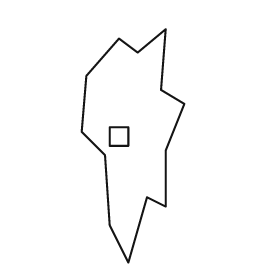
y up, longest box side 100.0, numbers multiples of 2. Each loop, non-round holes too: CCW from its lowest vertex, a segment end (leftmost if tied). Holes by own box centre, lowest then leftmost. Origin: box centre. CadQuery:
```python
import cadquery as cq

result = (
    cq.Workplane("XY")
    .moveTo(-2.0, -50.0)
    .lineTo(6.0, -22.0)
    .lineTo(14.0, -26.0)
    .lineTo(14.0, -2.0)
    .lineTo(22.0, 18.0)
    .lineTo(12.0, 24.0)
    .lineTo(14.0, 50.0)
    .lineTo(2.0, 40.0)
    .lineTo(-6.0, 46.0)
    .lineTo(-20.0, 30.0)
    .lineTo(-22.0, 6.0)
    .lineTo(-12.0, -4.0)
    .lineTo(-10.0, -34.0)
    .close()
    .moveTo(-10.0, 0.0)
    .lineTo(-2.0, 0.0)
    .lineTo(-2.0, 8.0)
    .lineTo(-10.0, 8.0)
    .close()
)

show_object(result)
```